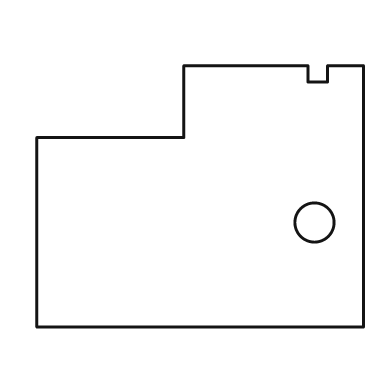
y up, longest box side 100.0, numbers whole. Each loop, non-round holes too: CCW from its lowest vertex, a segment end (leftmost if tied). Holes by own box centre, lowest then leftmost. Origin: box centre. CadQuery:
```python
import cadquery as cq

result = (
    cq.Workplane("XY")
    .moveTo(-50.0, -40.0)
    .lineTo(50.0, -40.0)
    .lineTo(50.0, 40.0)
    .lineTo(39.0, 40.0)
    .lineTo(39.0, 35.0)
    .lineTo(33.0, 35.0)
    .lineTo(33.0, 40.0)
    .lineTo(-5.0, 40.0)
    .lineTo(-5.0, 18.0)
    .lineTo(-50.0, 18.0)
    .close()
    .moveTo(35.0, -8.0)
    .circle(6.0)
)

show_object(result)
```